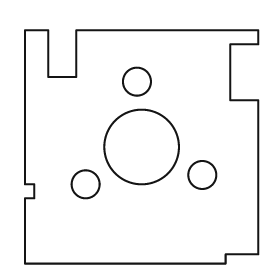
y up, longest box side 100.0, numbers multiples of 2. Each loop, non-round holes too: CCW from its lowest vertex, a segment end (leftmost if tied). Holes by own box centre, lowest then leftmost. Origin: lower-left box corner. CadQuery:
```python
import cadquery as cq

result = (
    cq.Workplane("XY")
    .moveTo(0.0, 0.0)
    .lineTo(86.0, 0.0)
    .lineTo(86.0, 4.0)
    .lineTo(100.0, 4.0)
    .lineTo(100.0, 70.0)
    .lineTo(88.0, 70.0)
    .lineTo(88.0, 94.0)
    .lineTo(100.0, 94.0)
    .lineTo(100.0, 100.0)
    .lineTo(22.0, 100.0)
    .lineTo(22.0, 80.0)
    .lineTo(10.0, 80.0)
    .lineTo(10.0, 100.0)
    .lineTo(0.0, 100.0)
    .lineTo(0.0, 34.0)
    .lineTo(4.0, 34.0)
    .lineTo(4.0, 28.0)
    .lineTo(0.0, 28.0)
    .close()
    .moveTo(26.0, 34.0)
    .circle(6.0)
    .moveTo(76.0, 38.0)
    .circle(6.0)
    .moveTo(50.0, 50.0)
    .circle(16.0)
    .moveTo(48.0, 78.0)
    .circle(6.0)
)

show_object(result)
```